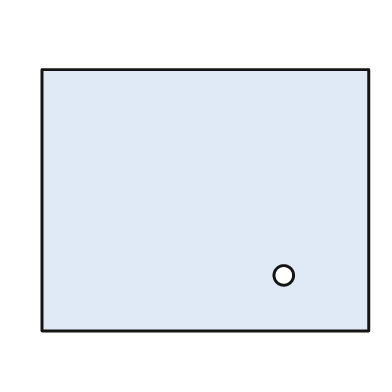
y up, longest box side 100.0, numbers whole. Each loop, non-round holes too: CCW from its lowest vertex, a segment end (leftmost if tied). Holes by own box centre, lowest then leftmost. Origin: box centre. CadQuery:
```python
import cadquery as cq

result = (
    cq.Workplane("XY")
    .moveTo(-50.0, -40.0)
    .lineTo(50.0, -40.0)
    .lineTo(50.0, 40.0)
    .lineTo(-50.0, 40.0)
    .close()
    .moveTo(24.0, -23.0)
    .circle(3.0)
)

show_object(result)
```